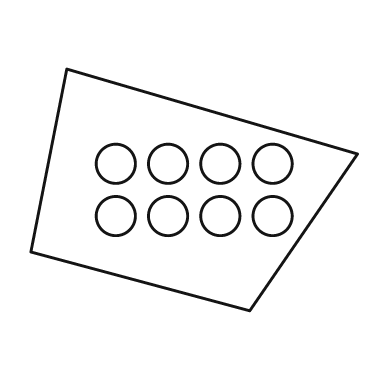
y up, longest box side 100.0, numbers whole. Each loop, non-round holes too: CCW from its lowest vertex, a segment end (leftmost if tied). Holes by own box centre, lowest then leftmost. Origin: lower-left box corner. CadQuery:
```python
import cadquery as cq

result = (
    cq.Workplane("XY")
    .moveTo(67.0, 0.0)
    .lineTo(100.0, 48.0)
    .lineTo(11.0, 74.0)
    .lineTo(0.0, 18.0)
    .close()
    .moveTo(26.0, 29.0)
    .circle(6.0)
    .moveTo(42.0, 29.0)
    .circle(6.0)
    .moveTo(58.0, 29.0)
    .circle(6.0)
    .moveTo(74.0, 29.0)
    .circle(6.0)
    .moveTo(26.0, 45.0)
    .circle(6.0)
    .moveTo(42.0, 45.0)
    .circle(6.0)
    .moveTo(58.0, 45.0)
    .circle(6.0)
    .moveTo(74.0, 45.0)
    .circle(6.0)
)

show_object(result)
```